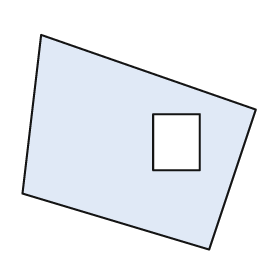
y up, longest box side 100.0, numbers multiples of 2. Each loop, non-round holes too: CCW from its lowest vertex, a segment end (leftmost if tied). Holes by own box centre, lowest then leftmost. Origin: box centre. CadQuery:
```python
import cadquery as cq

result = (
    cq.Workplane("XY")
    .moveTo(30.0, -46.0)
    .lineTo(50.0, 14.0)
    .lineTo(-42.0, 46.0)
    .lineTo(-50.0, -22.0)
    .close()
    .moveTo(6.0, -12.0)
    .lineTo(26.0, -12.0)
    .lineTo(26.0, 12.0)
    .lineTo(6.0, 12.0)
    .close()
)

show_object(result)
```